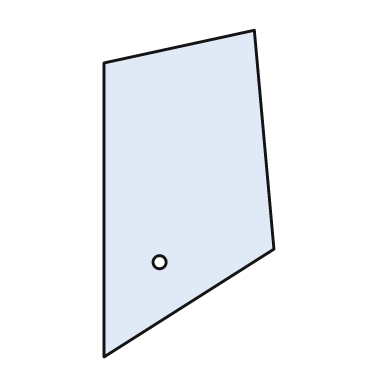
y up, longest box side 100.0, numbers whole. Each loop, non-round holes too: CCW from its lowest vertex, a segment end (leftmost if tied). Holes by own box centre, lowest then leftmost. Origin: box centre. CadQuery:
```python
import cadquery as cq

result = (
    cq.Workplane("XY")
    .moveTo(-26.0, -50.0)
    .lineTo(26.0, -17.0)
    .lineTo(20.0, 50.0)
    .lineTo(-26.0, 40.0)
    .close()
    .moveTo(-9.0, -21.0)
    .circle(2.0)
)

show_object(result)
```